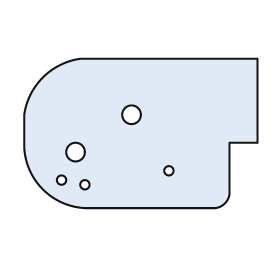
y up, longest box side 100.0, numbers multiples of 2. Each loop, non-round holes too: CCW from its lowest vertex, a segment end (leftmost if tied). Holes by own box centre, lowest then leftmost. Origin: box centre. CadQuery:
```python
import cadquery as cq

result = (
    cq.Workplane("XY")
    .moveTo(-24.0, -32.0)
    .lineTo(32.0, -32.0)
    .threePointArc((36.0, -30.0), (38.0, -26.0))
    .lineTo(38.0, -4.0)
    .lineTo(50.0, -4.0)
    .lineTo(50.0, 32.0)
    .lineTo(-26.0, 32.0)
    .threePointArc((-42.0, 24.0), (-50.0, 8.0))
    .lineTo(-50.0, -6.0)
    .threePointArc((-42.0, -24.0), (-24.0, -32.0))
    .close()
    .moveTo(-24.0, -22.0)
    .circle(2.0)
    .moveTo(-34.0, -20.0)
    .circle(2.0)
    .moveTo(12.0, -16.0)
    .circle(2.0)
    .moveTo(-28.0, -8.0)
    .circle(4.0)
    .moveTo(-4.0, 8.0)
    .circle(4.0)
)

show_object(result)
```